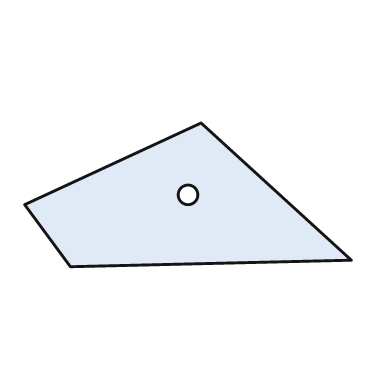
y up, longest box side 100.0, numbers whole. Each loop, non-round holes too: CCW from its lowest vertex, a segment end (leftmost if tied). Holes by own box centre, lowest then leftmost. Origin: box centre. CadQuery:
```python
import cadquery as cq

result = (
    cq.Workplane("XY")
    .moveTo(-36.0, -22.0)
    .lineTo(50.0, -20.0)
    .lineTo(4.0, 22.0)
    .lineTo(-50.0, -3.0)
    .close()
    .moveTo(0.0, 0.0)
    .circle(3.0)
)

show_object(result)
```